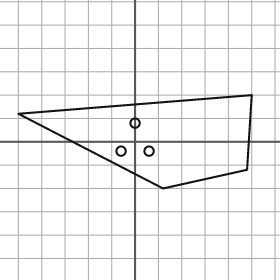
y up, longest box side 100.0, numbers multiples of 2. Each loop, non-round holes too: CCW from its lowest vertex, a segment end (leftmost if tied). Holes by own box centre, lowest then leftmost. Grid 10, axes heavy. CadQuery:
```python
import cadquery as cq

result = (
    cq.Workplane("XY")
    .moveTo(12.0, -20.0)
    .lineTo(48.0, -12.0)
    .lineTo(50.0, 20.0)
    .lineTo(-50.0, 12.0)
    .close()
    .moveTo(-6.0, -4.0)
    .circle(2.0)
    .moveTo(6.0, -4.0)
    .circle(2.0)
    .moveTo(0.0, 8.0)
    .circle(2.0)
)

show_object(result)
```